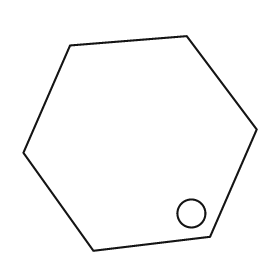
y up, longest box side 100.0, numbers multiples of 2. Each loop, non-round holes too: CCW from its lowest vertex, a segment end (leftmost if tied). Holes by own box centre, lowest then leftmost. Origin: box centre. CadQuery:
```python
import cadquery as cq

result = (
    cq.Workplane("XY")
    .moveTo(-20.0, -46.0)
    .lineTo(30.0, -40.0)
    .lineTo(50.0, 6.0)
    .lineTo(20.0, 46.0)
    .lineTo(-30.0, 42.0)
    .lineTo(-50.0, -4.0)
    .close()
    .moveTo(22.0, -30.0)
    .circle(6.0)
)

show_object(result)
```